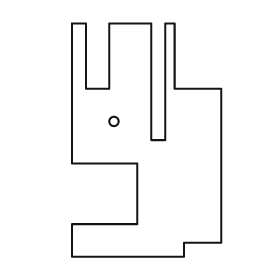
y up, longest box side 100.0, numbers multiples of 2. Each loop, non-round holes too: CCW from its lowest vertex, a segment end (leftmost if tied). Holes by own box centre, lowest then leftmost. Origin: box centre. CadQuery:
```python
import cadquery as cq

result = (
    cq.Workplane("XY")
    .moveTo(-32.0, -50.0)
    .lineTo(16.0, -50.0)
    .lineTo(16.0, -44.0)
    .lineTo(32.0, -44.0)
    .lineTo(32.0, 22.0)
    .lineTo(12.0, 22.0)
    .lineTo(12.0, 50.0)
    .lineTo(8.0, 50.0)
    .lineTo(8.0, 0.0)
    .lineTo(2.0, 0.0)
    .lineTo(2.0, 50.0)
    .lineTo(-16.0, 50.0)
    .lineTo(-16.0, 22.0)
    .lineTo(-26.0, 22.0)
    .lineTo(-26.0, 50.0)
    .lineTo(-32.0, 50.0)
    .lineTo(-32.0, -10.0)
    .lineTo(-4.0, -10.0)
    .lineTo(-4.0, -36.0)
    .lineTo(-32.0, -36.0)
    .close()
    .moveTo(-14.0, 8.0)
    .circle(2.0)
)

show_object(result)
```